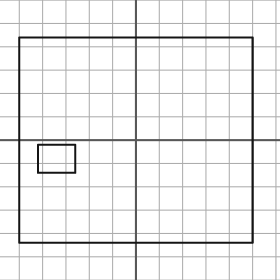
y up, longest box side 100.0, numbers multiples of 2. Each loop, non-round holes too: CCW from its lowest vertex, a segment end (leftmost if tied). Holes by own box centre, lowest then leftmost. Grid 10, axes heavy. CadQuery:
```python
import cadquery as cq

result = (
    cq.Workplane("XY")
    .moveTo(-50.0, -44.0)
    .lineTo(50.0, -44.0)
    .lineTo(50.0, 44.0)
    .lineTo(-50.0, 44.0)
    .close()
    .moveTo(-42.0, -14.0)
    .lineTo(-26.0, -14.0)
    .lineTo(-26.0, -2.0)
    .lineTo(-42.0, -2.0)
    .close()
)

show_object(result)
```